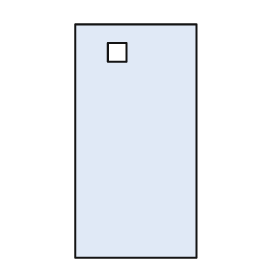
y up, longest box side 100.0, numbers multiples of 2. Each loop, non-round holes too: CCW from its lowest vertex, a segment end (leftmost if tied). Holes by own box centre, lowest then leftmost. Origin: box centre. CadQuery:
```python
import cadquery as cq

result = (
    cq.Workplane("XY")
    .moveTo(-26.0, -50.0)
    .lineTo(26.0, -50.0)
    .lineTo(26.0, 50.0)
    .lineTo(-26.0, 50.0)
    .close()
    .moveTo(-12.0, 34.0)
    .lineTo(-4.0, 34.0)
    .lineTo(-4.0, 42.0)
    .lineTo(-12.0, 42.0)
    .close()
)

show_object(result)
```